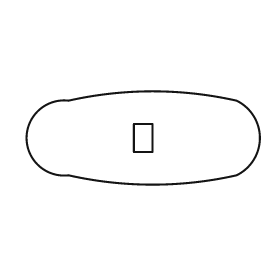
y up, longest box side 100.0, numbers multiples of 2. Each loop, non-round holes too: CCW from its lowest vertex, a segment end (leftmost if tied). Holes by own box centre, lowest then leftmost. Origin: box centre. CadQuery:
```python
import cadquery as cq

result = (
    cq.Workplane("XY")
    .moveTo(-32.0, -16.0)
    .threePointArc((4.0, -20.0), (40.0, -16.0))
    .threePointArc((50.0, 0.0), (40.0, 16.0))
    .threePointArc((4.0, 20.0), (-32.0, 16.0))
    .threePointArc((-50.0, 0.0), (-32.0, -16.0))
    .close()
    .moveTo(-4.0, -6.0)
    .lineTo(4.0, -6.0)
    .lineTo(4.0, 6.0)
    .lineTo(-4.0, 6.0)
    .close()
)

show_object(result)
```